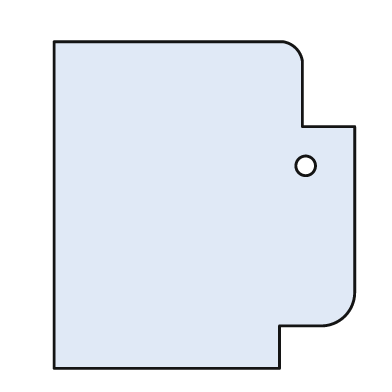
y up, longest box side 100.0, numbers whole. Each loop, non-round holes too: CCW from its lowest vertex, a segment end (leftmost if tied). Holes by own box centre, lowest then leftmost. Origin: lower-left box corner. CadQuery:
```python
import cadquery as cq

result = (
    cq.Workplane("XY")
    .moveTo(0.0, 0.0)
    .lineTo(69.0, 0.0)
    .lineTo(69.0, 13.0)
    .lineTo(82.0, 13.0)
    .threePointArc((89.0, 16.0), (92.0, 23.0))
    .lineTo(92.0, 74.0)
    .lineTo(76.0, 74.0)
    .lineTo(76.0, 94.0)
    .threePointArc((74.0, 98.0), (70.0, 100.0))
    .lineTo(0.0, 100.0)
    .close()
    .moveTo(77.0, 62.0)
    .circle(3.0)
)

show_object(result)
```